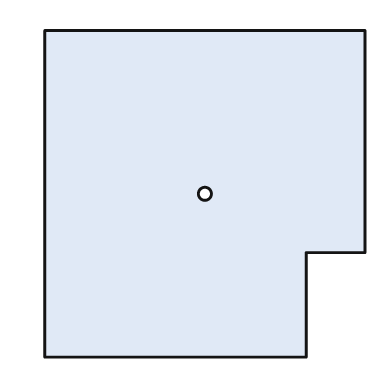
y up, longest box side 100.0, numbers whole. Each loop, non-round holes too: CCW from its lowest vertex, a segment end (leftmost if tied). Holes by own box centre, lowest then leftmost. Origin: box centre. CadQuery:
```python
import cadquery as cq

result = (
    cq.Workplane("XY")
    .moveTo(-49.0, -50.0)
    .lineTo(31.0, -50.0)
    .lineTo(31.0, -18.0)
    .lineTo(49.0, -18.0)
    .lineTo(49.0, 50.0)
    .lineTo(-49.0, 50.0)
    .close()
    .moveTo(0.0, 0.0)
    .circle(2.0)
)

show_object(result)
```